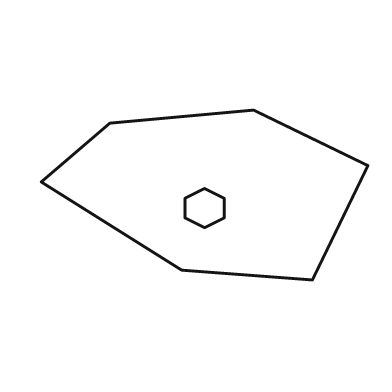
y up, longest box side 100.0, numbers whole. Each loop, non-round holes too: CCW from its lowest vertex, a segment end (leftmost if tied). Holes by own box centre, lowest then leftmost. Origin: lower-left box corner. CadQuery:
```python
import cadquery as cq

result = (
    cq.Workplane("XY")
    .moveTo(83.0, 0.0)
    .lineTo(100.0, 35.0)
    .lineTo(65.0, 52.0)
    .lineTo(21.0, 48.0)
    .lineTo(0.0, 30.0)
    .lineTo(43.0, 3.0)
    .close()
    .moveTo(50.0, 16.0)
    .lineTo(56.0, 19.0)
    .lineTo(56.0, 25.0)
    .lineTo(50.0, 28.0)
    .lineTo(44.0, 25.0)
    .lineTo(44.0, 19.0)
    .close()
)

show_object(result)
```